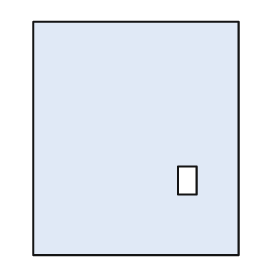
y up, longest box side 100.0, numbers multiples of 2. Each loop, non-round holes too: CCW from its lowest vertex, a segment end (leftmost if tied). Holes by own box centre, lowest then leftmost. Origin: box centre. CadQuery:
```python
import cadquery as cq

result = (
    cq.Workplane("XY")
    .moveTo(-44.0, -50.0)
    .lineTo(44.0, -50.0)
    .lineTo(44.0, 50.0)
    .lineTo(-44.0, 50.0)
    .close()
    .moveTo(18.0, -24.0)
    .lineTo(26.0, -24.0)
    .lineTo(26.0, -12.0)
    .lineTo(18.0, -12.0)
    .close()
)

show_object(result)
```